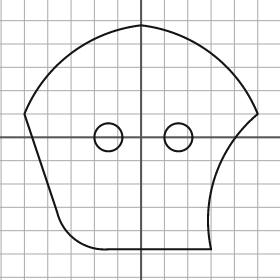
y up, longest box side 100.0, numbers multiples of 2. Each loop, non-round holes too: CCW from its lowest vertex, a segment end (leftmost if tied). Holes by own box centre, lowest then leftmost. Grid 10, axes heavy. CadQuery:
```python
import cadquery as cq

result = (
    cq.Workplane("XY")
    .moveTo(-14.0, -48.0)
    .lineTo(30.0, -48.0)
    .threePointArc((32.0, -16.0), (50.0, 10.0))
    .threePointArc((30.0, 36.0), (0.0, 48.0))
    .threePointArc((-30.0, 36.0), (-50.0, 10.0))
    .lineTo(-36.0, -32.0)
    .threePointArc((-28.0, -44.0), (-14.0, -48.0))
    .close()
    .moveTo(-14.0, 0.0)
    .circle(6.0)
    .moveTo(16.0, 0.0)
    .circle(6.0)
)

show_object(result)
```